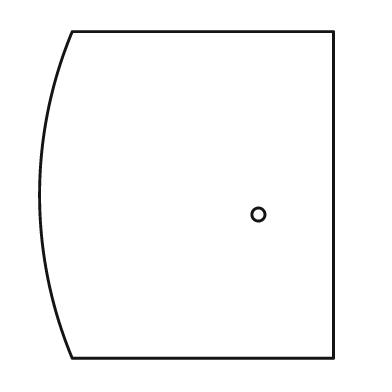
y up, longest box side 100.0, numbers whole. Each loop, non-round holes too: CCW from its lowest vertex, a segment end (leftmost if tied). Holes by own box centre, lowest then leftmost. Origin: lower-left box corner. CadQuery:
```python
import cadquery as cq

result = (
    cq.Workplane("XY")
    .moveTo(10.0, 0.0)
    .lineTo(90.0, 0.0)
    .lineTo(90.0, 100.0)
    .lineTo(10.0, 100.0)
    .threePointArc((0.0, 50.0), (10.0, 0.0))
    .close()
    .moveTo(67.0, 44.0)
    .circle(2.0)
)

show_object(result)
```